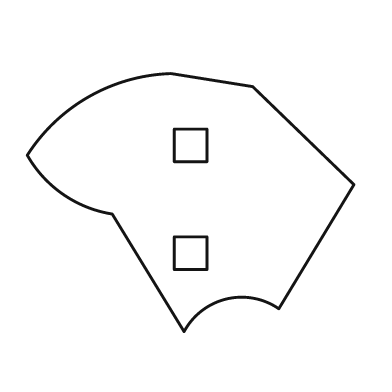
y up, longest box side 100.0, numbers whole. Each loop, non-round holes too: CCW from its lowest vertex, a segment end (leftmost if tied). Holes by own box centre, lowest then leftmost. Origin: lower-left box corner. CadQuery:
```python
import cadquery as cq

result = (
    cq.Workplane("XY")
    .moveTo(48.0, 0.0)
    .threePointArc((61.0, 10.0), (77.0, 7.0))
    .lineTo(100.0, 45.0)
    .lineTo(69.0, 75.0)
    .lineTo(44.0, 79.0)
    .threePointArc((19.0, 72.0), (0.0, 54.0))
    .threePointArc((11.0, 42.0), (26.0, 36.0))
    .close()
    .moveTo(45.0, 19.0)
    .lineTo(55.0, 19.0)
    .lineTo(55.0, 29.0)
    .lineTo(45.0, 29.0)
    .close()
    .moveTo(45.0, 52.0)
    .lineTo(55.0, 52.0)
    .lineTo(55.0, 62.0)
    .lineTo(45.0, 62.0)
    .close()
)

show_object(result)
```